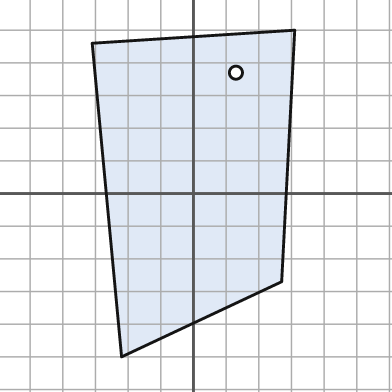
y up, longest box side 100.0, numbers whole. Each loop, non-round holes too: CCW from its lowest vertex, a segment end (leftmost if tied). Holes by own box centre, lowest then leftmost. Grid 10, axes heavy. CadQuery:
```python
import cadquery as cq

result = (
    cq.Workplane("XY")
    .moveTo(-22.0, -50.0)
    .lineTo(27.0, -27.0)
    .lineTo(31.0, 50.0)
    .lineTo(-31.0, 46.0)
    .close()
    .moveTo(13.0, 37.0)
    .circle(2.0)
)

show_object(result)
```